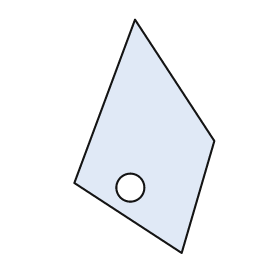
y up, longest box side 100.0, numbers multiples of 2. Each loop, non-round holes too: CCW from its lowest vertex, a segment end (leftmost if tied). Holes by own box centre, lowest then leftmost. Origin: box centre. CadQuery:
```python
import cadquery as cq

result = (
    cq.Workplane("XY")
    .moveTo(16.0, -50.0)
    .lineTo(30.0, -2.0)
    .lineTo(-4.0, 50.0)
    .lineTo(-30.0, -20.0)
    .close()
    .moveTo(-6.0, -22.0)
    .circle(6.0)
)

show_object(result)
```